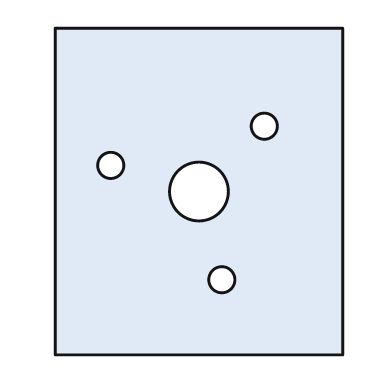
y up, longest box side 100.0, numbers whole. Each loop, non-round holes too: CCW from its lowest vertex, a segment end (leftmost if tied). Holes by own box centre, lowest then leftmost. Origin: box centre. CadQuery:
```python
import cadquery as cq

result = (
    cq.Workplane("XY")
    .moveTo(-44.0, -50.0)
    .lineTo(44.0, -50.0)
    .lineTo(44.0, 50.0)
    .lineTo(-44.0, 50.0)
    .close()
    .moveTo(7.0, -27.0)
    .circle(4.0)
    .moveTo(0.0, 0.0)
    .circle(9.0)
    .moveTo(-27.0, 8.0)
    .circle(4.0)
    .moveTo(20.0, 20.0)
    .circle(4.0)
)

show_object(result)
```